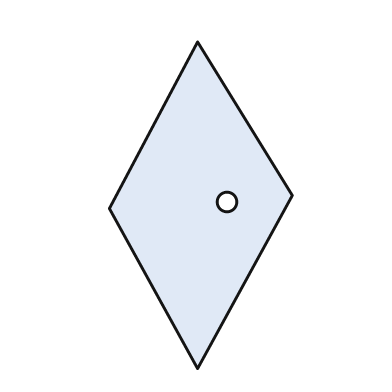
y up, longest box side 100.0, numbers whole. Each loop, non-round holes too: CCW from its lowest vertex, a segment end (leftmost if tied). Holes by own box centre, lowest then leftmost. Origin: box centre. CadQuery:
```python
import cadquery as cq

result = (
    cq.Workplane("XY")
    .moveTo(-1.0, -50.0)
    .lineTo(28.0, 3.0)
    .lineTo(-1.0, 50.0)
    .lineTo(-28.0, -1.0)
    .close()
    .moveTo(8.0, 1.0)
    .circle(3.0)
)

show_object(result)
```